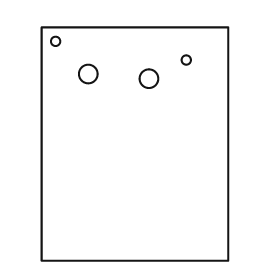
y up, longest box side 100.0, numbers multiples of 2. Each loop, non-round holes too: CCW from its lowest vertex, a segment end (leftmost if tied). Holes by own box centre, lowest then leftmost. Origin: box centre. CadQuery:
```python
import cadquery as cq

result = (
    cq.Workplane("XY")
    .moveTo(-40.0, -50.0)
    .lineTo(40.0, -50.0)
    .lineTo(40.0, 50.0)
    .lineTo(-40.0, 50.0)
    .close()
    .moveTo(6.0, 28.0)
    .circle(4.0)
    .moveTo(-20.0, 30.0)
    .circle(4.0)
    .moveTo(22.0, 36.0)
    .circle(2.0)
    .moveTo(-34.0, 44.0)
    .circle(2.0)
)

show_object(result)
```